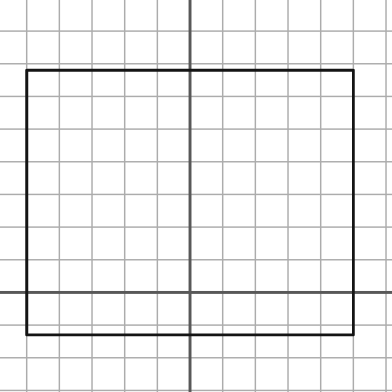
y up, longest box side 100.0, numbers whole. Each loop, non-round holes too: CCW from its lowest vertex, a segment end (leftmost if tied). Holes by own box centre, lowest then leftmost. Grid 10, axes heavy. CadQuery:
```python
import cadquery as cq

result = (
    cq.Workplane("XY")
    .moveTo(-50.0, -13.0)
    .lineTo(50.0, -13.0)
    .lineTo(50.0, 68.0)
    .lineTo(-50.0, 68.0)
    .close()
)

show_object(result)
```